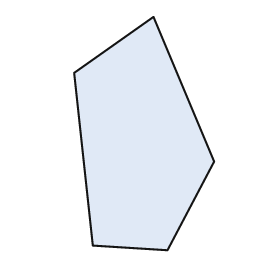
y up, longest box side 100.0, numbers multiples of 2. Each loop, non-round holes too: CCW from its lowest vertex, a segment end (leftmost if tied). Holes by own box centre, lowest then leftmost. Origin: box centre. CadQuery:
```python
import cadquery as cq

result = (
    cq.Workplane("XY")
    .moveTo(10.0, -50.0)
    .lineTo(30.0, -12.0)
    .lineTo(4.0, 50.0)
    .lineTo(-30.0, 26.0)
    .lineTo(-22.0, -48.0)
    .close()
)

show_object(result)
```